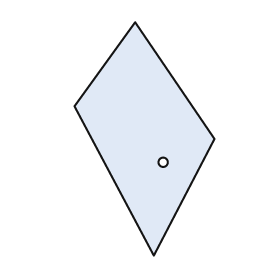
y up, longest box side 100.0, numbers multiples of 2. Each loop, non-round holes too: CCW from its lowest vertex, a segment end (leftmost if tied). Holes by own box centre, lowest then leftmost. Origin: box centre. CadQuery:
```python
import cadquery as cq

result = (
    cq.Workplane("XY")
    .moveTo(4.0, -50.0)
    .lineTo(30.0, 0.0)
    .lineTo(-4.0, 50.0)
    .lineTo(-30.0, 14.0)
    .close()
    .moveTo(8.0, -10.0)
    .circle(2.0)
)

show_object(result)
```